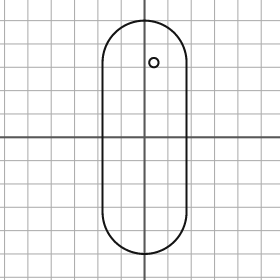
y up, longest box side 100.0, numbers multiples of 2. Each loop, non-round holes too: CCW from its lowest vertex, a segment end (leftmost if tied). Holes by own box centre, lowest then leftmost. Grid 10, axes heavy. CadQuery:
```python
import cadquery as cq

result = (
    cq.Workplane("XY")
    .moveTo(-18.0, -32.0)
    .threePointArc((0.0, -50.0), (18.0, -32.0))
    .lineTo(18.0, 32.0)
    .threePointArc((0.0, 50.0), (-18.0, 32.0))
    .close()
    .moveTo(4.0, 32.0)
    .circle(2.0)
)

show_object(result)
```